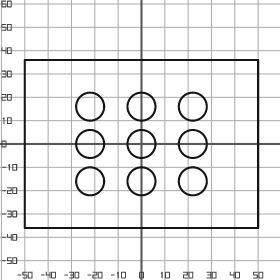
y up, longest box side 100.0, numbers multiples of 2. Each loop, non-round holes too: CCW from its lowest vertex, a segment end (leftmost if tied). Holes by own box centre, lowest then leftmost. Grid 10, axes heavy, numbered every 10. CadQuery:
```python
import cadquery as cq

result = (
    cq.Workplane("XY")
    .moveTo(-50.0, -36.0)
    .lineTo(50.0, -36.0)
    .lineTo(50.0, 36.0)
    .lineTo(-50.0, 36.0)
    .close()
    .moveTo(-22.0, -16.0)
    .circle(6.0)
    .moveTo(0.0, -16.0)
    .circle(6.0)
    .moveTo(22.0, -16.0)
    .circle(6.0)
    .moveTo(-22.0, 0.0)
    .circle(6.0)
    .moveTo(0.0, 0.0)
    .circle(6.0)
    .moveTo(22.0, 0.0)
    .circle(6.0)
    .moveTo(-22.0, 16.0)
    .circle(6.0)
    .moveTo(0.0, 16.0)
    .circle(6.0)
    .moveTo(22.0, 16.0)
    .circle(6.0)
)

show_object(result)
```